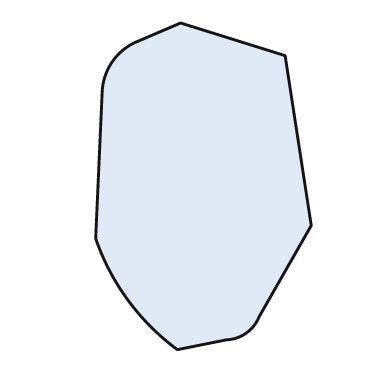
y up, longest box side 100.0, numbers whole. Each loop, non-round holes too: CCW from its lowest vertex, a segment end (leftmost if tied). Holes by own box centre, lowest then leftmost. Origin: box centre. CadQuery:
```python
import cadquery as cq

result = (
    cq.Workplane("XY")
    .moveTo(-8.0, -50.0)
    .lineTo(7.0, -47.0)
    .threePointArc((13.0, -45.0), (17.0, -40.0))
    .lineTo(33.0, -12.0)
    .lineTo(25.0, 40.0)
    .lineTo(-7.0, 50.0)
    .lineTo(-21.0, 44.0)
    .threePointArc((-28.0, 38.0), (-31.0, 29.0))
    .lineTo(-33.0, -16.0)
    .threePointArc((-23.0, -35.0), (-8.0, -50.0))
    .close()
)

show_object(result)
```